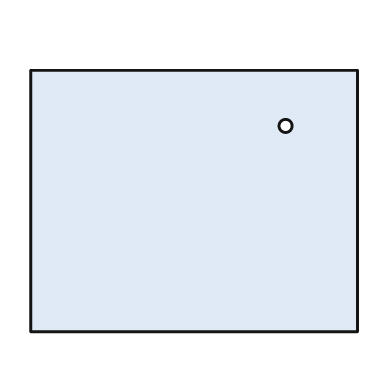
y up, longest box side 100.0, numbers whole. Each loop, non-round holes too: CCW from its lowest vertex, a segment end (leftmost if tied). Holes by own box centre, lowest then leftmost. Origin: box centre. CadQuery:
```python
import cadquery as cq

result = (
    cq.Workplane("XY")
    .moveTo(-50.0, -40.0)
    .lineTo(50.0, -40.0)
    .lineTo(50.0, 40.0)
    .lineTo(-50.0, 40.0)
    .close()
    .moveTo(28.0, 23.0)
    .circle(2.0)
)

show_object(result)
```